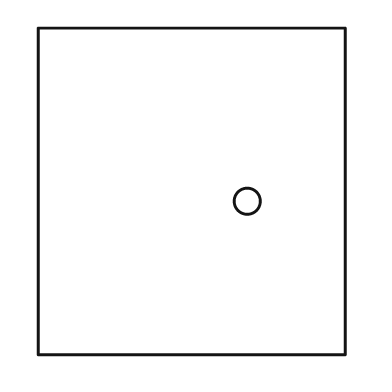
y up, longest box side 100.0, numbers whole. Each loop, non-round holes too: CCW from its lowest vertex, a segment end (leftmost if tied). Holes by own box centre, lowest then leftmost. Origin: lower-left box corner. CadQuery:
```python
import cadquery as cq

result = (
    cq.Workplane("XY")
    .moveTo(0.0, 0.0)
    .lineTo(94.0, 0.0)
    .lineTo(94.0, 100.0)
    .lineTo(0.0, 100.0)
    .close()
    .moveTo(64.0, 47.0)
    .circle(4.0)
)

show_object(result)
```